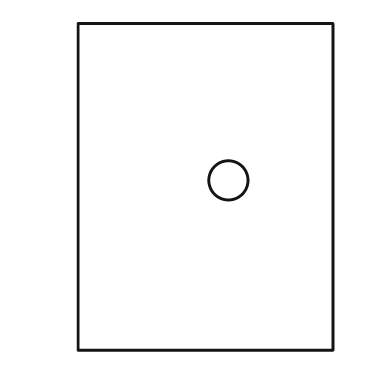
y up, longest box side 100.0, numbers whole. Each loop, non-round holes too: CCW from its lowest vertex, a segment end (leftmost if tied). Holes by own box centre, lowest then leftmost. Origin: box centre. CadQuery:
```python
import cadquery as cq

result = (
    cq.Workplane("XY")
    .moveTo(-39.0, -50.0)
    .lineTo(39.0, -50.0)
    .lineTo(39.0, 50.0)
    .lineTo(-39.0, 50.0)
    .close()
    .moveTo(7.0, 2.0)
    .circle(6.0)
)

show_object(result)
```